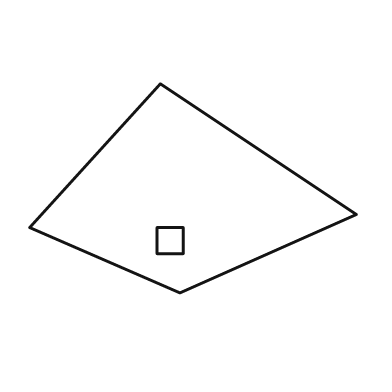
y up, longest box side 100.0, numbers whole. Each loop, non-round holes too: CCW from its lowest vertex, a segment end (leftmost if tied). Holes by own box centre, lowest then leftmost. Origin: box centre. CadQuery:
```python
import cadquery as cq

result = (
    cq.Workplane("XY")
    .moveTo(-4.0, -32.0)
    .lineTo(50.0, -8.0)
    .lineTo(-10.0, 32.0)
    .lineTo(-50.0, -12.0)
    .close()
    .moveTo(-11.0, -20.0)
    .lineTo(-3.0, -20.0)
    .lineTo(-3.0, -12.0)
    .lineTo(-11.0, -12.0)
    .close()
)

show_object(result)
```